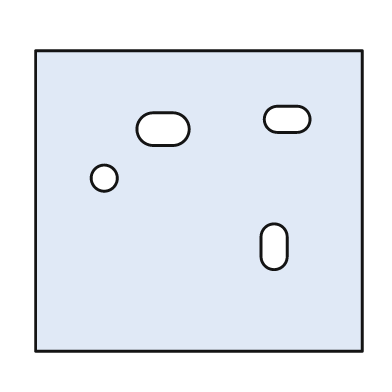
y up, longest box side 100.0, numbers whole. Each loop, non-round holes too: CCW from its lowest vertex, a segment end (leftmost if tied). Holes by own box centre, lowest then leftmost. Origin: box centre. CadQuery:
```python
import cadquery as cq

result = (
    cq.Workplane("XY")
    .moveTo(-50.0, -46.0)
    .lineTo(50.0, -46.0)
    .lineTo(50.0, 46.0)
    .lineTo(-50.0, 46.0)
    .close()
    .moveTo(19.0, -17.0)
    .threePointArc((23.0, -21.0), (27.0, -17.0))
    .lineTo(27.0, -11.0)
    .threePointArc((23.0, -7.0), (19.0, -11.0))
    .close()
    .moveTo(-29.0, 7.0)
    .circle(4.0)
    .moveTo(-14.0, 17.0)
    .lineTo(-8.0, 17.0)
    .threePointArc((-3.0, 22.0), (-8.0, 27.0))
    .lineTo(-14.0, 27.0)
    .threePointArc((-19.0, 22.0), (-14.0, 17.0))
    .close()
    .moveTo(24.0, 21.0)
    .lineTo(30.0, 21.0)
    .threePointArc((34.0, 25.0), (30.0, 29.0))
    .lineTo(24.0, 29.0)
    .threePointArc((20.0, 25.0), (24.0, 21.0))
    .close()
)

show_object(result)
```